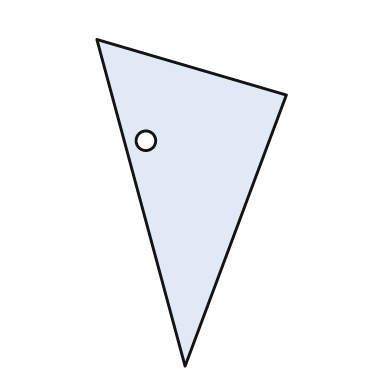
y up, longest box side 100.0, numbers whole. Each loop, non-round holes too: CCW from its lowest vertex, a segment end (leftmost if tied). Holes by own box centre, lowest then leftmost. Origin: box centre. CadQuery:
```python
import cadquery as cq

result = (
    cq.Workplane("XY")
    .moveTo(-2.0, -50.0)
    .lineTo(29.0, 33.0)
    .lineTo(-29.0, 50.0)
    .close()
    .moveTo(-14.0, 19.0)
    .circle(3.0)
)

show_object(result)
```